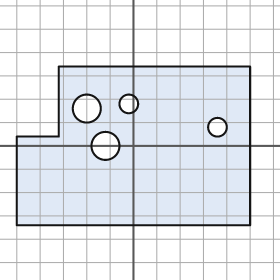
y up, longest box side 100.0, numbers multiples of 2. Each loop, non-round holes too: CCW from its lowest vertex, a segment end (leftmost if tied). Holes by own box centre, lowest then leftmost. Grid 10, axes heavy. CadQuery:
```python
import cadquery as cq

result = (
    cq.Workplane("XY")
    .moveTo(-50.0, -34.0)
    .lineTo(50.0, -34.0)
    .lineTo(50.0, 34.0)
    .lineTo(-32.0, 34.0)
    .lineTo(-32.0, 4.0)
    .lineTo(-50.0, 4.0)
    .close()
    .moveTo(-12.0, 0.0)
    .circle(6.0)
    .moveTo(36.0, 8.0)
    .circle(4.0)
    .moveTo(-20.0, 16.0)
    .circle(6.0)
    .moveTo(-2.0, 18.0)
    .circle(4.0)
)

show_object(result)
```